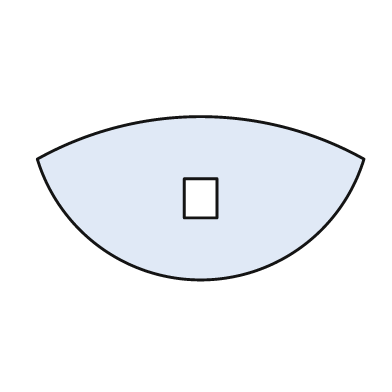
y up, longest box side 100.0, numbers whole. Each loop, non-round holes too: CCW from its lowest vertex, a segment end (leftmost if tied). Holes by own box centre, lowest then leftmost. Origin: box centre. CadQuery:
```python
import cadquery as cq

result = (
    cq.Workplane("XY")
    .moveTo(-50.0, 12.0)
    .threePointArc((0.0, -25.0), (50.0, 12.0))
    .threePointArc((0.0, 25.0), (-50.0, 12.0))
    .close()
    .moveTo(-5.0, -6.0)
    .lineTo(5.0, -6.0)
    .lineTo(5.0, 6.0)
    .lineTo(-5.0, 6.0)
    .close()
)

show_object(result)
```